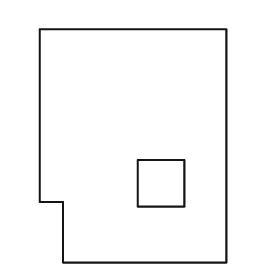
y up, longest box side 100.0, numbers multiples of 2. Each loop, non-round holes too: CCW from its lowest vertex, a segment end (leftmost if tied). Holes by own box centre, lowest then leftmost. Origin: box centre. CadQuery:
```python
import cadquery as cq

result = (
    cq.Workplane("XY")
    .moveTo(-30.0, -50.0)
    .lineTo(40.0, -50.0)
    .lineTo(40.0, 50.0)
    .lineTo(-40.0, 50.0)
    .lineTo(-40.0, -24.0)
    .lineTo(-30.0, -24.0)
    .close()
    .moveTo(2.0, -26.0)
    .lineTo(22.0, -26.0)
    .lineTo(22.0, -6.0)
    .lineTo(2.0, -6.0)
    .close()
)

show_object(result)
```